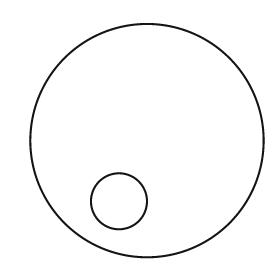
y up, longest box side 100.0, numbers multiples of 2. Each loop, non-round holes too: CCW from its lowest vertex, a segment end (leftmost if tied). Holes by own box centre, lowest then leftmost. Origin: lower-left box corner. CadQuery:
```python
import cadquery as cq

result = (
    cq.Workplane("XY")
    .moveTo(50.0, 50.0)
    .circle(50.0)
    .moveTo(38.0, 24.0)
    .circle(12.0)
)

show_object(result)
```